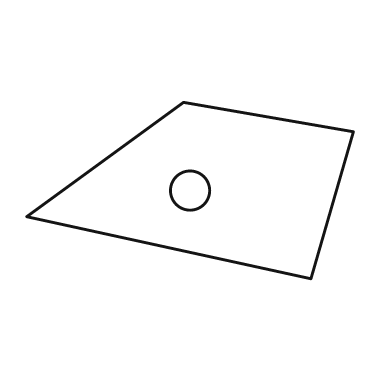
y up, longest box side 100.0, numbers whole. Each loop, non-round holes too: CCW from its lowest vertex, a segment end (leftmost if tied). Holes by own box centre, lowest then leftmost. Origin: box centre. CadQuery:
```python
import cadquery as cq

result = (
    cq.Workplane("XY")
    .moveTo(37.0, -27.0)
    .lineTo(50.0, 18.0)
    .lineTo(-2.0, 27.0)
    .lineTo(-50.0, -8.0)
    .close()
    .moveTo(0.0, 0.0)
    .circle(6.0)
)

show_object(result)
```